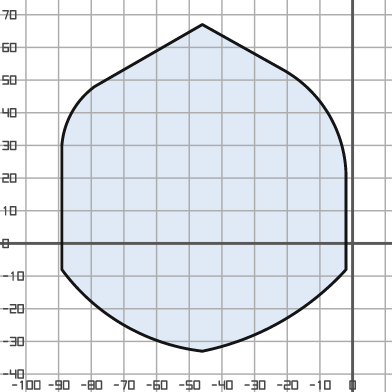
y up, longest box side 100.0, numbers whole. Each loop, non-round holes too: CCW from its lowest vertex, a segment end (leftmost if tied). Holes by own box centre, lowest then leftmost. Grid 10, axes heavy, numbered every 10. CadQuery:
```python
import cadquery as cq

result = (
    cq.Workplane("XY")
    .moveTo(-46.0, -33.0)
    .threePointArc((-22.0, -24.0), (-2.0, -8.0))
    .lineTo(-2.0, 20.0)
    .threePointArc((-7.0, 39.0), (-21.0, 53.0))
    .lineTo(-46.0, 67.0)
    .lineTo(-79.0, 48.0)
    .threePointArc((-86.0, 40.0), (-89.0, 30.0))
    .lineTo(-89.0, -8.0)
    .threePointArc((-70.0, -25.0), (-46.0, -33.0))
    .close()
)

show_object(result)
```